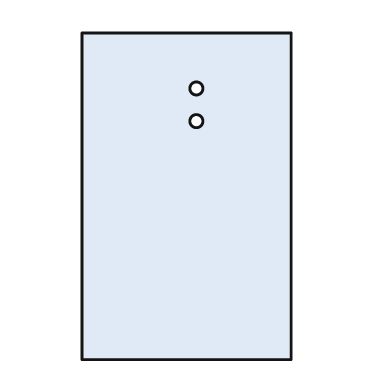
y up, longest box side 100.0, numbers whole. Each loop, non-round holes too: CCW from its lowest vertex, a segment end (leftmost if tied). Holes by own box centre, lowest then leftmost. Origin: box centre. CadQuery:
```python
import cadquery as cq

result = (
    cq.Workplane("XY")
    .moveTo(-32.0, -50.0)
    .lineTo(32.0, -50.0)
    .lineTo(32.0, 50.0)
    .lineTo(-32.0, 50.0)
    .close()
    .moveTo(3.0, 23.0)
    .circle(2.0)
    .moveTo(3.0, 33.0)
    .circle(2.0)
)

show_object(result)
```